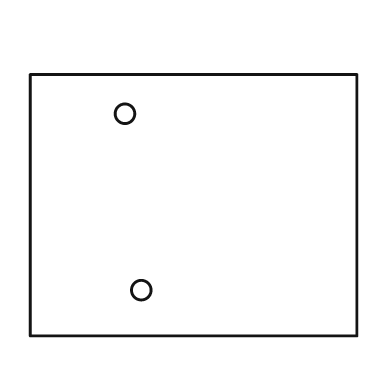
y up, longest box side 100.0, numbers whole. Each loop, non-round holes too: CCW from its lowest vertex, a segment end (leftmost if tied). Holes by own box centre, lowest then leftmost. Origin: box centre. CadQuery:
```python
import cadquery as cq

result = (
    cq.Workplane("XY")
    .moveTo(-50.0, -40.0)
    .lineTo(50.0, -40.0)
    .lineTo(50.0, 40.0)
    .lineTo(-50.0, 40.0)
    .close()
    .moveTo(-16.0, -26.0)
    .circle(3.0)
    .moveTo(-21.0, 28.0)
    .circle(3.0)
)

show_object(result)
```